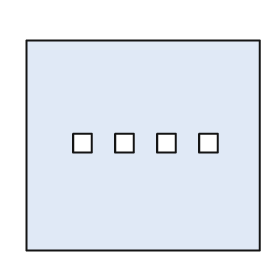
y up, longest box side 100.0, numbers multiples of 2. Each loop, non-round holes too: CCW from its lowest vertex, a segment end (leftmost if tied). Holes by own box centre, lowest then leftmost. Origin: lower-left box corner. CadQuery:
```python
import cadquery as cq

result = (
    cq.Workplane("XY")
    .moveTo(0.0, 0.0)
    .lineTo(100.0, 0.0)
    .lineTo(100.0, 90.0)
    .lineTo(0.0, 90.0)
    .close()
    .moveTo(20.0, 42.0)
    .lineTo(28.0, 42.0)
    .lineTo(28.0, 50.0)
    .lineTo(20.0, 50.0)
    .close()
    .moveTo(38.0, 42.0)
    .lineTo(46.0, 42.0)
    .lineTo(46.0, 50.0)
    .lineTo(38.0, 50.0)
    .close()
    .moveTo(56.0, 42.0)
    .lineTo(64.0, 42.0)
    .lineTo(64.0, 50.0)
    .lineTo(56.0, 50.0)
    .close()
    .moveTo(74.0, 42.0)
    .lineTo(82.0, 42.0)
    .lineTo(82.0, 50.0)
    .lineTo(74.0, 50.0)
    .close()
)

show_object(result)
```